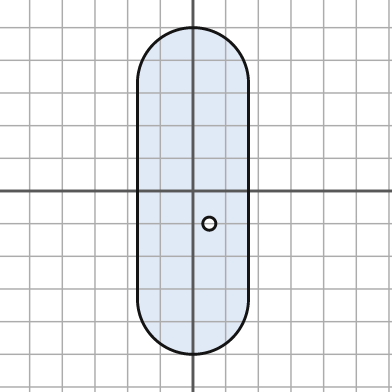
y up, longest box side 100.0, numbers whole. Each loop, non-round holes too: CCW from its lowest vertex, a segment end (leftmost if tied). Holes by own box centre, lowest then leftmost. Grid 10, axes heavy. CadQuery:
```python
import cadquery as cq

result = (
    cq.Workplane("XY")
    .moveTo(-17.0, -33.0)
    .threePointArc((0.0, -50.0), (17.0, -33.0))
    .lineTo(17.0, 33.0)
    .threePointArc((0.0, 50.0), (-17.0, 33.0))
    .close()
    .moveTo(5.0, -10.0)
    .circle(2.0)
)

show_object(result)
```